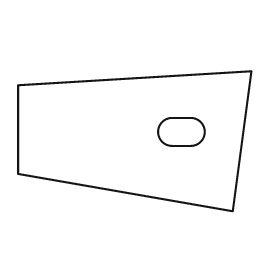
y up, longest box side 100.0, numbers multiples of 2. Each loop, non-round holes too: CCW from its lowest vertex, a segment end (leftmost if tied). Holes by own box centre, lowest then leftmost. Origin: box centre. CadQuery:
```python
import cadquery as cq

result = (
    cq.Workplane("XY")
    .moveTo(42.0, -30.0)
    .lineTo(50.0, 30.0)
    .lineTo(-50.0, 24.0)
    .lineTo(-50.0, -14.0)
    .close()
    .moveTo(16.0, -2.0)
    .lineTo(24.0, -2.0)
    .threePointArc((30.0, 4.0), (24.0, 10.0))
    .lineTo(16.0, 10.0)
    .threePointArc((10.0, 4.0), (16.0, -2.0))
    .close()
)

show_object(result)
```